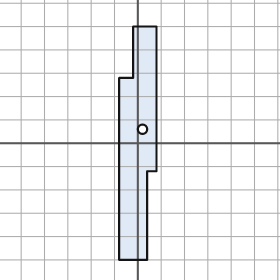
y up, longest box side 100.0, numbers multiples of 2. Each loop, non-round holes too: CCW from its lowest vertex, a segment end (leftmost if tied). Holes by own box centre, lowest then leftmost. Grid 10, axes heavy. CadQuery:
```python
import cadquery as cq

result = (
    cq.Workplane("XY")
    .moveTo(-8.0, -50.0)
    .lineTo(4.0, -50.0)
    .lineTo(4.0, -12.0)
    .lineTo(8.0, -12.0)
    .lineTo(8.0, 50.0)
    .lineTo(-2.0, 50.0)
    .lineTo(-2.0, 28.0)
    .lineTo(-8.0, 28.0)
    .close()
    .moveTo(2.0, 6.0)
    .circle(2.0)
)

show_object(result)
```